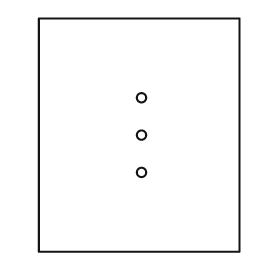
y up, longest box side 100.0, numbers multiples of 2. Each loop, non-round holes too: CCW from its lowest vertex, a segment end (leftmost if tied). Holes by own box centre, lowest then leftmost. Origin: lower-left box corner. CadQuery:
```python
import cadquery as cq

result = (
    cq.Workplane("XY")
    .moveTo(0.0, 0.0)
    .lineTo(86.0, 0.0)
    .lineTo(86.0, 100.0)
    .lineTo(0.0, 100.0)
    .close()
    .moveTo(44.0, 34.0)
    .circle(2.0)
    .moveTo(44.0, 50.0)
    .circle(2.0)
    .moveTo(44.0, 66.0)
    .circle(2.0)
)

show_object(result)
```